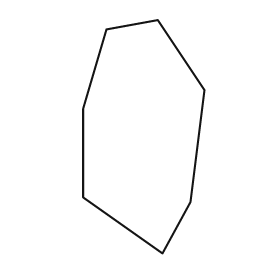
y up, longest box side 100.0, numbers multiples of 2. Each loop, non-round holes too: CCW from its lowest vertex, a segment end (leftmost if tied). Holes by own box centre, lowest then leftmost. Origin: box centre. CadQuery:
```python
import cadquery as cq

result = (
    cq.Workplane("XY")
    .moveTo(8.0, -50.0)
    .lineTo(20.0, -28.0)
    .lineTo(26.0, 20.0)
    .lineTo(6.0, 50.0)
    .lineTo(-16.0, 46.0)
    .lineTo(-26.0, 12.0)
    .lineTo(-26.0, -26.0)
    .close()
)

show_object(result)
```